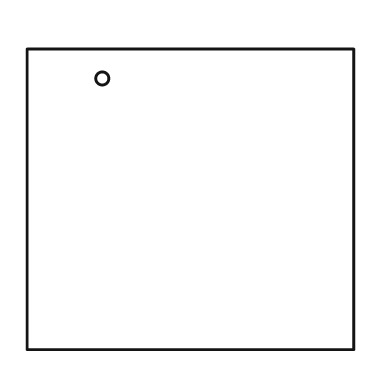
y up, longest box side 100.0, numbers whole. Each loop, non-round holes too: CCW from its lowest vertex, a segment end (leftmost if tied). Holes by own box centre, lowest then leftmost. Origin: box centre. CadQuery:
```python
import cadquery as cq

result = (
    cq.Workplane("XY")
    .moveTo(-50.0, -46.0)
    .lineTo(50.0, -46.0)
    .lineTo(50.0, 46.0)
    .lineTo(-50.0, 46.0)
    .close()
    .moveTo(-27.0, 37.0)
    .circle(2.0)
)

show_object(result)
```